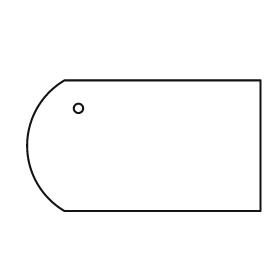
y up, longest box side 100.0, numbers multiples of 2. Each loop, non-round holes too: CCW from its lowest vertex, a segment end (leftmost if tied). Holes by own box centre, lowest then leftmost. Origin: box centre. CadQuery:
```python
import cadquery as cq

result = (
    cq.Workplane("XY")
    .moveTo(-34.0, -28.0)
    .lineTo(50.0, -28.0)
    .lineTo(50.0, 28.0)
    .lineTo(-34.0, 28.0)
    .threePointArc((-50.0, 0.0), (-34.0, -28.0))
    .close()
    .moveTo(-28.0, 16.0)
    .circle(2.0)
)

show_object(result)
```